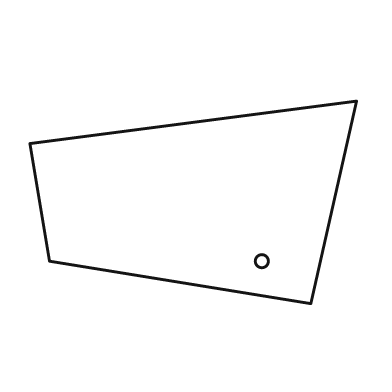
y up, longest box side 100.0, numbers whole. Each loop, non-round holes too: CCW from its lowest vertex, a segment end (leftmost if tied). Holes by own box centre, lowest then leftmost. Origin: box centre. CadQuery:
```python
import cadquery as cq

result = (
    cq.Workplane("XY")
    .moveTo(36.0, -31.0)
    .lineTo(50.0, 31.0)
    .lineTo(-50.0, 18.0)
    .lineTo(-44.0, -18.0)
    .close()
    .moveTo(21.0, -18.0)
    .circle(2.0)
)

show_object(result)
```